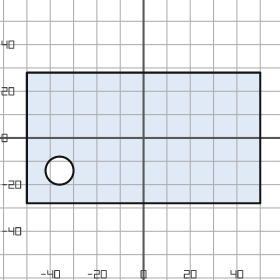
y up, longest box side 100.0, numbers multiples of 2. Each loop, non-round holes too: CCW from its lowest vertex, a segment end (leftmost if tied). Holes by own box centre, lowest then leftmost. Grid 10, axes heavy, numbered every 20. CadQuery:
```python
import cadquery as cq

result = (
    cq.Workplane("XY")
    .moveTo(-50.0, -28.0)
    .lineTo(50.0, -28.0)
    .lineTo(50.0, 28.0)
    .lineTo(-50.0, 28.0)
    .close()
    .moveTo(-36.0, -14.0)
    .circle(6.0)
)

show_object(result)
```